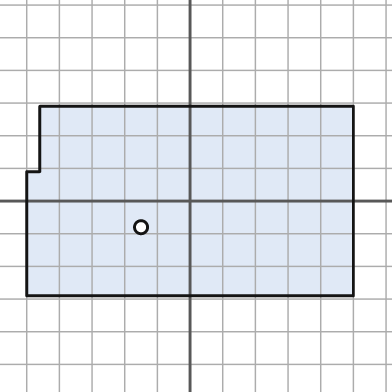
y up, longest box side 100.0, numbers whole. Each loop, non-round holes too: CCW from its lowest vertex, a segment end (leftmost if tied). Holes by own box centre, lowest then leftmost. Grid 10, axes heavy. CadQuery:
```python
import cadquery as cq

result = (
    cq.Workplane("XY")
    .moveTo(-50.0, -29.0)
    .lineTo(50.0, -29.0)
    .lineTo(50.0, 29.0)
    .lineTo(-46.0, 29.0)
    .lineTo(-46.0, 9.0)
    .lineTo(-50.0, 9.0)
    .close()
    .moveTo(-15.0, -8.0)
    .circle(2.0)
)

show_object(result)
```